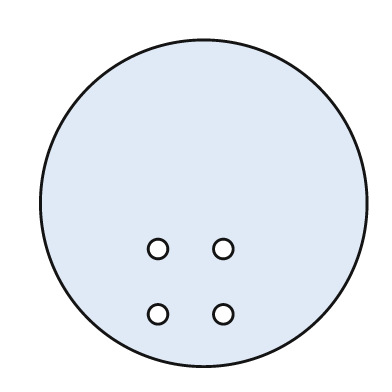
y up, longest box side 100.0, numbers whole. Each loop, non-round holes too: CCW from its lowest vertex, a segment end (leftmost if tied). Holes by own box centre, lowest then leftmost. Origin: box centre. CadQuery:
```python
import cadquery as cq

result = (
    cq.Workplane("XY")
    .moveTo(0.0, 0.0)
    .circle(50.0)
    .moveTo(-14.0, -34.0)
    .circle(3.0)
    .moveTo(6.0, -34.0)
    .circle(3.0)
    .moveTo(-14.0, -14.0)
    .circle(3.0)
    .moveTo(6.0, -14.0)
    .circle(3.0)
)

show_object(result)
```